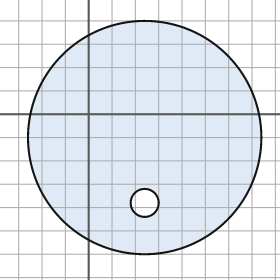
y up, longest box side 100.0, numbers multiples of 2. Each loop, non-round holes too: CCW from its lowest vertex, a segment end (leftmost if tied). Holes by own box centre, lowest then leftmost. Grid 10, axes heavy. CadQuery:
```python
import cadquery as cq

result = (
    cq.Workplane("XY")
    .moveTo(24.0, -10.0)
    .circle(50.0)
    .moveTo(24.0, -38.0)
    .circle(6.0)
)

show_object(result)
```